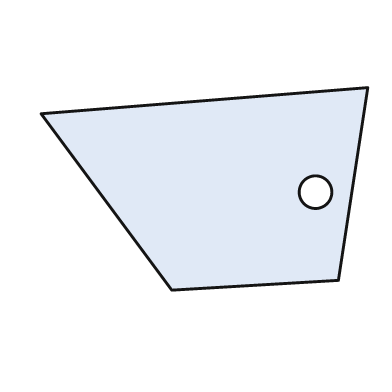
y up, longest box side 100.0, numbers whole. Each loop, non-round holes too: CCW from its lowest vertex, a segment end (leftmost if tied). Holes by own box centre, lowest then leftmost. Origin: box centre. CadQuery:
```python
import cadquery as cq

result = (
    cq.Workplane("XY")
    .moveTo(-10.0, -31.0)
    .lineTo(41.0, -28.0)
    .lineTo(50.0, 31.0)
    .lineTo(-50.0, 23.0)
    .close()
    .moveTo(34.0, -1.0)
    .circle(5.0)
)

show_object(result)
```